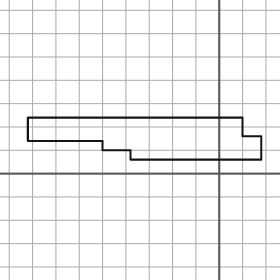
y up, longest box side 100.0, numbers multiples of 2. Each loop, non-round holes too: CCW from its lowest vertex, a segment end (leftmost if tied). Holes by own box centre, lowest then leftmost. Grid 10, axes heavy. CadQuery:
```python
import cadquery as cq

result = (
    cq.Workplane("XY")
    .moveTo(-38.0, 6.0)
    .lineTo(18.0, 6.0)
    .lineTo(18.0, 16.0)
    .lineTo(10.0, 16.0)
    .lineTo(10.0, 24.0)
    .lineTo(-82.0, 24.0)
    .lineTo(-82.0, 14.0)
    .lineTo(-50.0, 14.0)
    .lineTo(-50.0, 10.0)
    .lineTo(-38.0, 10.0)
    .close()
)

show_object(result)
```